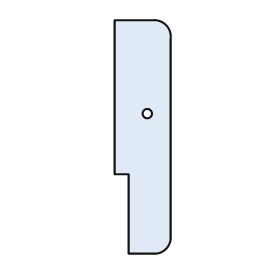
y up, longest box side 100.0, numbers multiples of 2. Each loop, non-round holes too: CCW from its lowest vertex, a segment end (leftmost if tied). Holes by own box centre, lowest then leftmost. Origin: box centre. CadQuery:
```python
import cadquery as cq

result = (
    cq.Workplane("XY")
    .moveTo(-6.0, -50.0)
    .lineTo(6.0, -50.0)
    .threePointArc((10.0, -48.0), (12.0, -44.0))
    .lineTo(12.0, 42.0)
    .threePointArc((10.0, 48.0), (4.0, 50.0))
    .lineTo(-12.0, 50.0)
    .lineTo(-12.0, -16.0)
    .lineTo(-6.0, -16.0)
    .close()
    .moveTo(2.0, 10.0)
    .circle(2.0)
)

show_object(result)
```